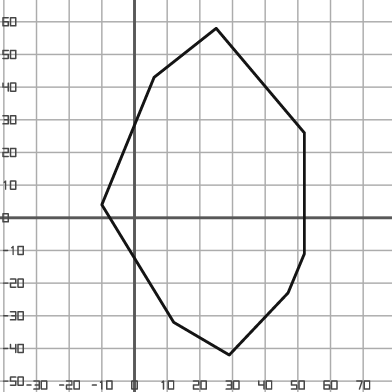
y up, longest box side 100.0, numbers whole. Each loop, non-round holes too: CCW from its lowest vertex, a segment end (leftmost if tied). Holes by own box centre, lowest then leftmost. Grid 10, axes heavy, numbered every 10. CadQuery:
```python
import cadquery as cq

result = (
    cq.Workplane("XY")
    .moveTo(29.0, -42.0)
    .lineTo(47.0, -23.0)
    .lineTo(52.0, -11.0)
    .lineTo(52.0, 26.0)
    .lineTo(25.0, 58.0)
    .lineTo(6.0, 43.0)
    .lineTo(-10.0, 4.0)
    .lineTo(12.0, -32.0)
    .close()
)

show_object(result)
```